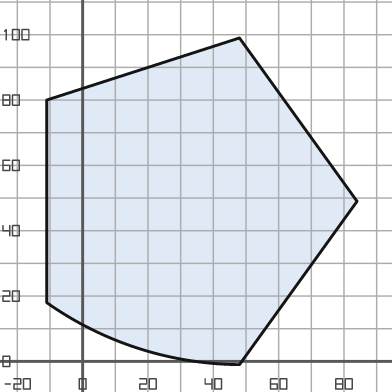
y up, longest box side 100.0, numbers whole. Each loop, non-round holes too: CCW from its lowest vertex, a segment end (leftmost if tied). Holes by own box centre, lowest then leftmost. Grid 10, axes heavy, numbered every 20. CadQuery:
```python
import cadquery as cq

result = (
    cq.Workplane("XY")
    .moveTo(48.0, -1.0)
    .lineTo(84.0, 49.0)
    .lineTo(48.0, 99.0)
    .lineTo(-11.0, 80.0)
    .lineTo(-11.0, 18.0)
    .threePointArc((17.0, 4.0), (48.0, -1.0))
    .close()
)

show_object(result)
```